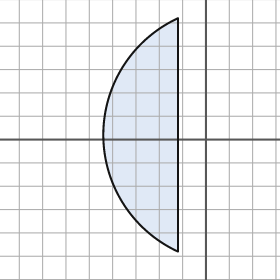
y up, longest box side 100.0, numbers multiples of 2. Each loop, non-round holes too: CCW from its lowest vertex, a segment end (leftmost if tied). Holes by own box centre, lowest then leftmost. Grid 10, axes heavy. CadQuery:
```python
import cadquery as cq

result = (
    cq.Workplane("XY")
    .moveTo(-12.0, -48.0)
    .lineTo(-12.0, 52.0)
    .threePointArc((-44.0, 2.0), (-12.0, -48.0))
    .close()
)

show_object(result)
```